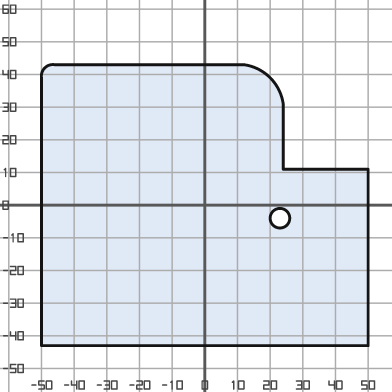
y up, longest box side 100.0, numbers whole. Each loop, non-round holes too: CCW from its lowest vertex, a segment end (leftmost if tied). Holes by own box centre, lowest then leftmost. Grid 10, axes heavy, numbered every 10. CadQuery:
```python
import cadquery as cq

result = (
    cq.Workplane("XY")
    .moveTo(-50.0, -43.0)
    .lineTo(50.0, -43.0)
    .lineTo(50.0, 11.0)
    .lineTo(24.0, 11.0)
    .lineTo(24.0, 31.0)
    .threePointArc((20.0, 39.0), (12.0, 43.0))
    .lineTo(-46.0, 43.0)
    .threePointArc((-49.0, 42.0), (-50.0, 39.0))
    .close()
    .moveTo(23.0, -4.0)
    .circle(3.0)
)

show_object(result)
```